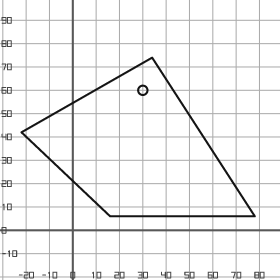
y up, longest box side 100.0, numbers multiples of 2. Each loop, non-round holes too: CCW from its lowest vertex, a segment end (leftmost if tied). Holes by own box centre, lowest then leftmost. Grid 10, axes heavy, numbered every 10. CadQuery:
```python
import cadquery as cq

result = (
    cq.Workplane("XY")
    .moveTo(16.0, 6.0)
    .lineTo(78.0, 6.0)
    .lineTo(34.0, 74.0)
    .lineTo(-22.0, 42.0)
    .close()
    .moveTo(30.0, 60.0)
    .circle(2.0)
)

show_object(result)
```